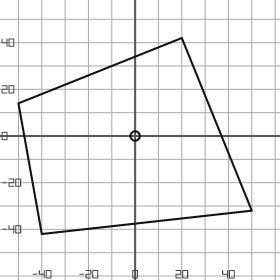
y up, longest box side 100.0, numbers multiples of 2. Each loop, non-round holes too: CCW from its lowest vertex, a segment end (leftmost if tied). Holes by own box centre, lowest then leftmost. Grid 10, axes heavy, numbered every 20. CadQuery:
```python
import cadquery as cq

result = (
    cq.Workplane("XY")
    .moveTo(-40.0, -42.0)
    .lineTo(50.0, -32.0)
    .lineTo(20.0, 42.0)
    .lineTo(-50.0, 14.0)
    .close()
    .moveTo(0.0, 0.0)
    .circle(2.0)
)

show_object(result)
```